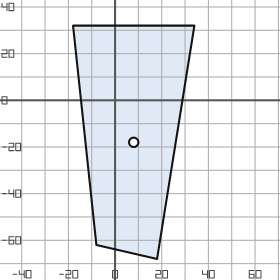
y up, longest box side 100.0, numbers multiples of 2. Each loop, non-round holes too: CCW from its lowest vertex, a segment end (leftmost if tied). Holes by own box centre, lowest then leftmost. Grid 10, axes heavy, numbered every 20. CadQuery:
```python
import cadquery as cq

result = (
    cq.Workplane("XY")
    .moveTo(18.0, -68.0)
    .lineTo(34.0, 32.0)
    .lineTo(-18.0, 32.0)
    .lineTo(-8.0, -62.0)
    .close()
    .moveTo(8.0, -18.0)
    .circle(2.0)
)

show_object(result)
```